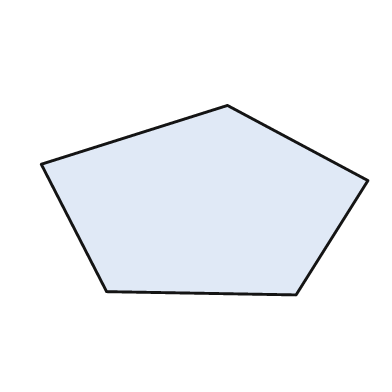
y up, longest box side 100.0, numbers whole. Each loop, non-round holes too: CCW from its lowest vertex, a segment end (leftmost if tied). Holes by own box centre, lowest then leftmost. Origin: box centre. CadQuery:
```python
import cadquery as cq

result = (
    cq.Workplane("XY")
    .moveTo(28.0, -29.0)
    .lineTo(50.0, 6.0)
    .lineTo(7.0, 29.0)
    .lineTo(-50.0, 11.0)
    .lineTo(-30.0, -28.0)
    .close()
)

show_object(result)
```